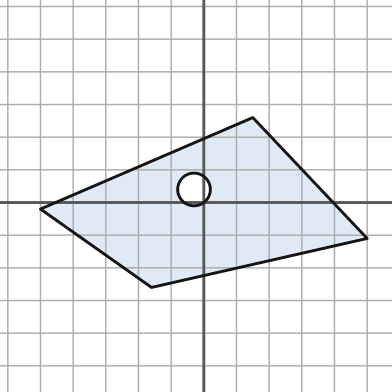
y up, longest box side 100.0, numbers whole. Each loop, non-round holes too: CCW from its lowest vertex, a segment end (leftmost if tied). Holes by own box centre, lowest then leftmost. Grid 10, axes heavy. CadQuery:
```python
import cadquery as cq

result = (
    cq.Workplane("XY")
    .moveTo(-16.0, -26.0)
    .lineTo(50.0, -11.0)
    .lineTo(15.0, 26.0)
    .lineTo(-50.0, -2.0)
    .close()
    .moveTo(-3.0, 4.0)
    .circle(5.0)
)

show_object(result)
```